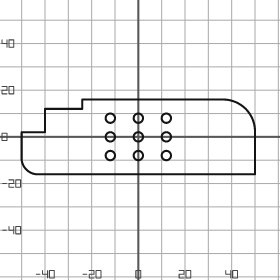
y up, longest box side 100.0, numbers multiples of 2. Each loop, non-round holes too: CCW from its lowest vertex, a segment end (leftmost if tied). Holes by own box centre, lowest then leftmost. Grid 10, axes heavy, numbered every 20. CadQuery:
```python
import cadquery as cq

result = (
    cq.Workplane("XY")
    .moveTo(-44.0, -16.0)
    .lineTo(50.0, -16.0)
    .lineTo(50.0, 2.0)
    .threePointArc((46.0, 12.0), (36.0, 16.0))
    .lineTo(-24.0, 16.0)
    .lineTo(-24.0, 12.0)
    .lineTo(-40.0, 12.0)
    .lineTo(-40.0, 2.0)
    .lineTo(-50.0, 2.0)
    .lineTo(-50.0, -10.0)
    .threePointArc((-48.0, -14.0), (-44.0, -16.0))
    .close()
    .moveTo(-12.0, -8.0)
    .circle(2.0)
    .moveTo(0.0, -8.0)
    .circle(2.0)
    .moveTo(12.0, -8.0)
    .circle(2.0)
    .moveTo(-12.0, 0.0)
    .circle(2.0)
    .moveTo(0.0, 0.0)
    .circle(2.0)
    .moveTo(12.0, 0.0)
    .circle(2.0)
    .moveTo(-12.0, 8.0)
    .circle(2.0)
    .moveTo(0.0, 8.0)
    .circle(2.0)
    .moveTo(12.0, 8.0)
    .circle(2.0)
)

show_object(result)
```